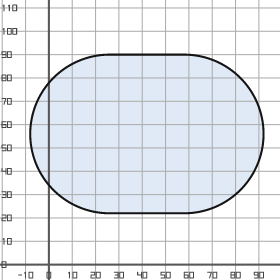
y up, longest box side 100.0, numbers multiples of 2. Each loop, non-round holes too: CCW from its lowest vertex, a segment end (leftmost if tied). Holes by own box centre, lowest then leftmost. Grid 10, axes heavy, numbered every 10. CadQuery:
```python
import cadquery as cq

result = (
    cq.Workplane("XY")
    .moveTo(26.0, 22.0)
    .lineTo(58.0, 22.0)
    .threePointArc((92.0, 56.0), (58.0, 90.0))
    .lineTo(26.0, 90.0)
    .threePointArc((-8.0, 56.0), (26.0, 22.0))
    .close()
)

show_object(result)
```